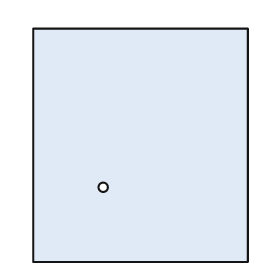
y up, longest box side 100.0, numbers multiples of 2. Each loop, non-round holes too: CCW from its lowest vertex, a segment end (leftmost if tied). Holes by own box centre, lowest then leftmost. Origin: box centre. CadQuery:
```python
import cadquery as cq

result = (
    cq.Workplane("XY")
    .moveTo(-46.0, -50.0)
    .lineTo(46.0, -50.0)
    .lineTo(46.0, 50.0)
    .lineTo(-46.0, 50.0)
    .close()
    .moveTo(-16.0, -18.0)
    .circle(2.0)
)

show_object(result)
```